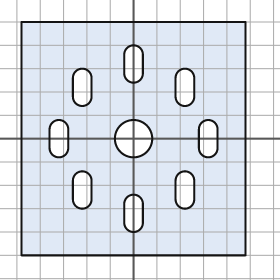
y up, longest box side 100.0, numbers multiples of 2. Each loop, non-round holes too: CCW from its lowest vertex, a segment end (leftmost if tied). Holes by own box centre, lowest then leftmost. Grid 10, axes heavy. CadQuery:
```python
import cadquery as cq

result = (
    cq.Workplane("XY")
    .moveTo(-48.0, -50.0)
    .lineTo(48.0, -50.0)
    .lineTo(48.0, 50.0)
    .lineTo(-48.0, 50.0)
    .close()
    .moveTo(-4.0, -36.0)
    .threePointArc((0.0, -40.0), (4.0, -36.0))
    .lineTo(4.0, -28.0)
    .threePointArc((0.0, -24.0), (-4.0, -28.0))
    .close()
    .moveTo(-26.0, -26.0)
    .threePointArc((-22.0, -30.0), (-18.0, -26.0))
    .lineTo(-18.0, -18.0)
    .threePointArc((-22.0, -14.0), (-26.0, -18.0))
    .close()
    .moveTo(18.0, -26.0)
    .threePointArc((22.0, -30.0), (26.0, -26.0))
    .lineTo(26.0, -18.0)
    .threePointArc((22.0, -14.0), (18.0, -18.0))
    .close()
    .moveTo(-36.0, -4.0)
    .threePointArc((-32.0, -8.0), (-28.0, -4.0))
    .lineTo(-28.0, 4.0)
    .threePointArc((-32.0, 8.0), (-36.0, 4.0))
    .close()
    .moveTo(0.0, 0.0)
    .circle(8.0)
    .moveTo(28.0, -4.0)
    .threePointArc((32.0, -8.0), (36.0, -4.0))
    .lineTo(36.0, 4.0)
    .threePointArc((32.0, 8.0), (28.0, 4.0))
    .close()
    .moveTo(-26.0, 18.0)
    .threePointArc((-22.0, 14.0), (-18.0, 18.0))
    .lineTo(-18.0, 26.0)
    .threePointArc((-22.0, 30.0), (-26.0, 26.0))
    .close()
    .moveTo(18.0, 18.0)
    .threePointArc((22.0, 14.0), (26.0, 18.0))
    .lineTo(26.0, 26.0)
    .threePointArc((22.0, 30.0), (18.0, 26.0))
    .close()
    .moveTo(-4.0, 28.0)
    .threePointArc((0.0, 24.0), (4.0, 28.0))
    .lineTo(4.0, 36.0)
    .threePointArc((0.0, 40.0), (-4.0, 36.0))
    .close()
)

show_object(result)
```